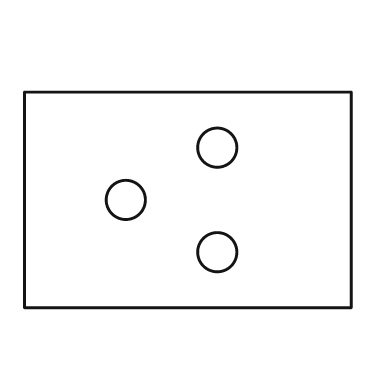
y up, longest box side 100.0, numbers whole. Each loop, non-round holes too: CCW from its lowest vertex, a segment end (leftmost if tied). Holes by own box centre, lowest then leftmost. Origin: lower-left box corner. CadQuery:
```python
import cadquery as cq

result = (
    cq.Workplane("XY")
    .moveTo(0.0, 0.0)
    .lineTo(100.0, 0.0)
    .lineTo(100.0, 66.0)
    .lineTo(0.0, 66.0)
    .close()
    .moveTo(59.0, 17.0)
    .circle(6.0)
    .moveTo(31.0, 33.0)
    .circle(6.0)
    .moveTo(59.0, 49.0)
    .circle(6.0)
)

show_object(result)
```